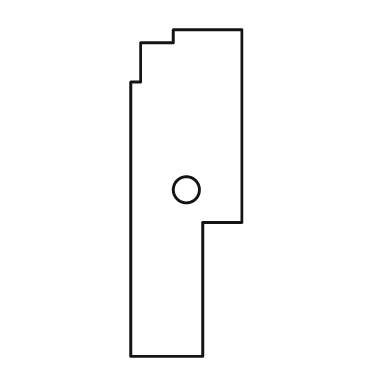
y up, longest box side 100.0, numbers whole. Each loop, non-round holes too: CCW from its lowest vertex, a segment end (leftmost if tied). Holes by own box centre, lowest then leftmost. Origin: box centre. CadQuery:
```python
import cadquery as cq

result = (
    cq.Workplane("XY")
    .moveTo(-17.0, -50.0)
    .lineTo(5.0, -50.0)
    .lineTo(5.0, -9.0)
    .lineTo(17.0, -9.0)
    .lineTo(17.0, 50.0)
    .lineTo(-4.0, 50.0)
    .lineTo(-4.0, 46.0)
    .lineTo(-14.0, 46.0)
    .lineTo(-14.0, 34.0)
    .lineTo(-17.0, 34.0)
    .close()
    .moveTo(0.0, 1.0)
    .circle(4.0)
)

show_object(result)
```